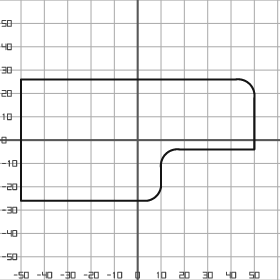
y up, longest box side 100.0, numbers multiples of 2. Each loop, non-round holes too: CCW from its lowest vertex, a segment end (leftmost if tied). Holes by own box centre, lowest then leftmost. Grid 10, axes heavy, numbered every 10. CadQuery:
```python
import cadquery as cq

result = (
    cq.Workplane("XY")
    .moveTo(-50.0, -26.0)
    .lineTo(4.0, -26.0)
    .threePointArc((8.0, -24.0), (10.0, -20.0))
    .lineTo(10.0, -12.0)
    .threePointArc((12.0, -6.0), (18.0, -4.0))
    .lineTo(50.0, -4.0)
    .lineTo(50.0, 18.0)
    .threePointArc((48.0, 24.0), (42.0, 26.0))
    .lineTo(-50.0, 26.0)
    .close()
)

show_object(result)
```